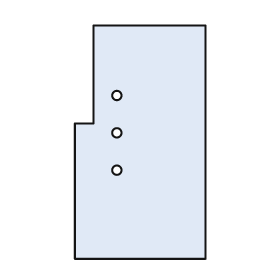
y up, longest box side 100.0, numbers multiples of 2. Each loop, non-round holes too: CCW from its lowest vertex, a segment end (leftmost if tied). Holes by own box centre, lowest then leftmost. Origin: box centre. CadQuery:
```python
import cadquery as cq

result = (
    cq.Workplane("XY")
    .moveTo(-28.0, -50.0)
    .lineTo(28.0, -50.0)
    .lineTo(28.0, 50.0)
    .lineTo(-20.0, 50.0)
    .lineTo(-20.0, 8.0)
    .lineTo(-28.0, 8.0)
    .close()
    .moveTo(-10.0, -12.0)
    .circle(2.0)
    .moveTo(-10.0, 4.0)
    .circle(2.0)
    .moveTo(-10.0, 20.0)
    .circle(2.0)
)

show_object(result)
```